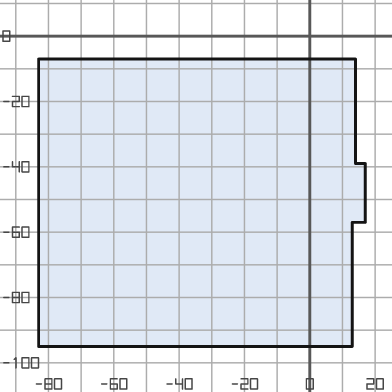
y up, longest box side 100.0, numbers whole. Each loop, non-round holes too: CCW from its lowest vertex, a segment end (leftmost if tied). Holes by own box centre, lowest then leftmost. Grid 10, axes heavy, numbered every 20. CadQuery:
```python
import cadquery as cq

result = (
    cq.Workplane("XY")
    .moveTo(-83.0, -95.0)
    .lineTo(13.0, -95.0)
    .lineTo(13.0, -57.0)
    .lineTo(17.0, -57.0)
    .lineTo(17.0, -39.0)
    .lineTo(14.0, -39.0)
    .lineTo(14.0, -7.0)
    .lineTo(-83.0, -7.0)
    .close()
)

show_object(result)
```